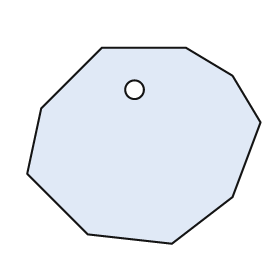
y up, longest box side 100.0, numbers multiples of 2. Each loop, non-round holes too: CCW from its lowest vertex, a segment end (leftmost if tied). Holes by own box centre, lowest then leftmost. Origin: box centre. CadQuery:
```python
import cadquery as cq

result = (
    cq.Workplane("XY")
    .moveTo(12.0, -42.0)
    .lineTo(38.0, -22.0)
    .lineTo(50.0, 10.0)
    .lineTo(38.0, 30.0)
    .lineTo(18.0, 42.0)
    .lineTo(-18.0, 42.0)
    .lineTo(-44.0, 16.0)
    .lineTo(-50.0, -12.0)
    .lineTo(-24.0, -38.0)
    .close()
    .moveTo(-4.0, 24.0)
    .circle(4.0)
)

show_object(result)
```